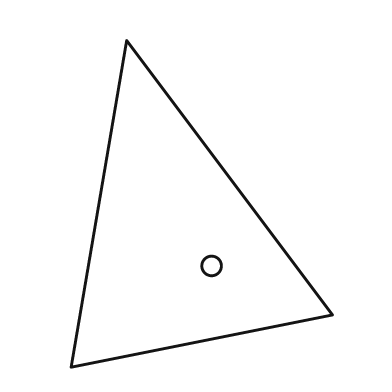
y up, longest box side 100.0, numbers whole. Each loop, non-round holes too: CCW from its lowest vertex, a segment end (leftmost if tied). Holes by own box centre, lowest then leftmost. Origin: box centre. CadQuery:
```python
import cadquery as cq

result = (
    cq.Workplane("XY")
    .moveTo(-40.0, -50.0)
    .lineTo(40.0, -34.0)
    .lineTo(-23.0, 50.0)
    .close()
    .moveTo(3.0, -19.0)
    .circle(3.0)
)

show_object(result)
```